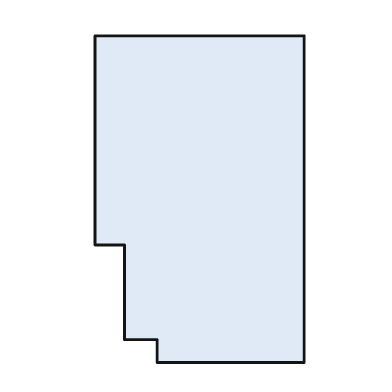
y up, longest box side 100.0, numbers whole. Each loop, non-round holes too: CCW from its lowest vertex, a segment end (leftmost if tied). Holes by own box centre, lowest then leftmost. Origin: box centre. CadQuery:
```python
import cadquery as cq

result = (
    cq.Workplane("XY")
    .moveTo(-13.0, -50.0)
    .lineTo(32.0, -50.0)
    .lineTo(32.0, 50.0)
    .lineTo(-32.0, 50.0)
    .lineTo(-32.0, -14.0)
    .lineTo(-23.0, -14.0)
    .lineTo(-23.0, -43.0)
    .lineTo(-13.0, -43.0)
    .close()
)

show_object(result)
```